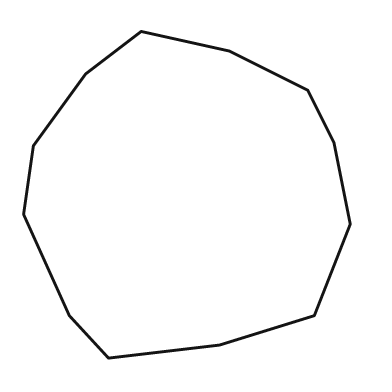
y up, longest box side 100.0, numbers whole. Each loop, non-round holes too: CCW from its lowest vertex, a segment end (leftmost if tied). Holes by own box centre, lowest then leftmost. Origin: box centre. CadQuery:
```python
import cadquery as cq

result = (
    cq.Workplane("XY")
    .moveTo(-24.0, -50.0)
    .lineTo(10.0, -46.0)
    .lineTo(39.0, -37.0)
    .lineTo(50.0, -9.0)
    .lineTo(45.0, 16.0)
    .lineTo(37.0, 32.0)
    .lineTo(13.0, 44.0)
    .lineTo(-14.0, 50.0)
    .lineTo(-31.0, 37.0)
    .lineTo(-47.0, 15.0)
    .lineTo(-50.0, -6.0)
    .lineTo(-36.0, -37.0)
    .close()
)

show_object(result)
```